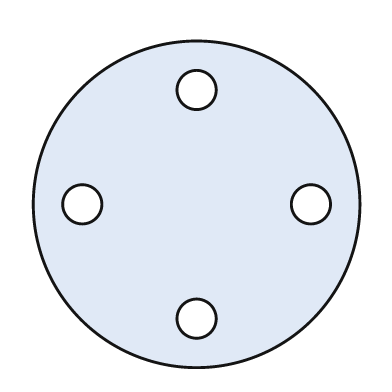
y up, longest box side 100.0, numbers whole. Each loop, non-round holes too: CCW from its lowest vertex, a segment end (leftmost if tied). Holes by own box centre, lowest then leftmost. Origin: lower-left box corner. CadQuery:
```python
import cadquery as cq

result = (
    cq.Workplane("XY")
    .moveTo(50.0, 50.0)
    .circle(50.0)
    .moveTo(50.0, 15.0)
    .circle(6.0)
    .moveTo(15.0, 50.0)
    .circle(6.0)
    .moveTo(85.0, 50.0)
    .circle(6.0)
    .moveTo(50.0, 85.0)
    .circle(6.0)
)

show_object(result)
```